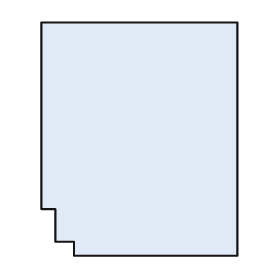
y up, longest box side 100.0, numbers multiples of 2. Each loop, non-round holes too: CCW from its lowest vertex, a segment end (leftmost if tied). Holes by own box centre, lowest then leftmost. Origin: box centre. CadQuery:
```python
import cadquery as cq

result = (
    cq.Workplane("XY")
    .moveTo(-28.0, -50.0)
    .lineTo(42.0, -50.0)
    .lineTo(42.0, 50.0)
    .lineTo(-42.0, 50.0)
    .lineTo(-42.0, -30.0)
    .lineTo(-36.0, -30.0)
    .lineTo(-36.0, -44.0)
    .lineTo(-28.0, -44.0)
    .close()
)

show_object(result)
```